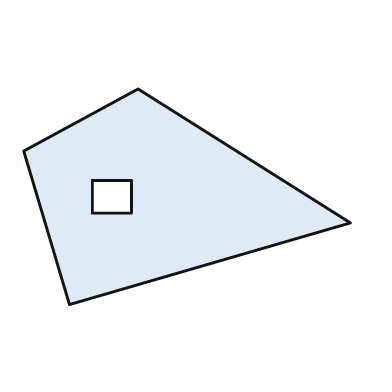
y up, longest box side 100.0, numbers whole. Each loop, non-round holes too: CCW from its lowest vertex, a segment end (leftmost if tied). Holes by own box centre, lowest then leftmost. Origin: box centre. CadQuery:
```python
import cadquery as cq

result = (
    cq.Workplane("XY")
    .moveTo(-36.0, -33.0)
    .lineTo(50.0, -8.0)
    .lineTo(-15.0, 33.0)
    .lineTo(-50.0, 14.0)
    .close()
    .moveTo(-29.0, -5.0)
    .lineTo(-17.0, -5.0)
    .lineTo(-17.0, 5.0)
    .lineTo(-29.0, 5.0)
    .close()
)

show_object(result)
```